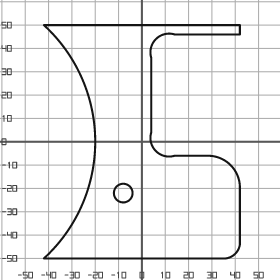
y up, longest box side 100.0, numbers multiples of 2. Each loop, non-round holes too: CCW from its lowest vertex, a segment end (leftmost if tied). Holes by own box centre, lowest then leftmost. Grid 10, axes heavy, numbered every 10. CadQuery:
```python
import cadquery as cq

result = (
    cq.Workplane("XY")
    .moveTo(-42.0, -50.0)
    .lineTo(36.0, -50.0)
    .threePointArc((40.0, -48.0), (42.0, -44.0))
    .lineTo(42.0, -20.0)
    .threePointArc((38.0, -10.0), (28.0, -6.0))
    .lineTo(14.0, -6.0)
    .threePointArc((6.0, -4.0), (4.0, 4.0))
    .lineTo(4.0, 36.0)
    .threePointArc((6.0, 44.0), (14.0, 46.0))
    .lineTo(42.0, 46.0)
    .lineTo(42.0, 50.0)
    .lineTo(-42.0, 50.0)
    .threePointArc((-20.0, 0.0), (-42.0, -50.0))
    .close()
    .moveTo(-8.0, -22.0)
    .circle(4.0)
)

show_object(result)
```